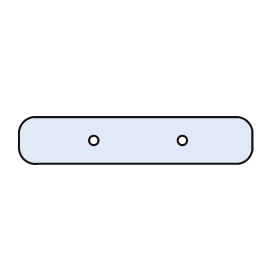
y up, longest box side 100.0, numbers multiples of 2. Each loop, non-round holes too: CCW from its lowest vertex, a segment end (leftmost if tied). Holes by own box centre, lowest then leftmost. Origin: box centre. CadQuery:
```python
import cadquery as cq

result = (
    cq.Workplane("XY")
    .moveTo(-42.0, -10.0)
    .lineTo(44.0, -10.0)
    .threePointArc((48.0, -8.0), (50.0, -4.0))
    .lineTo(50.0, 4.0)
    .threePointArc((48.0, 8.0), (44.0, 10.0))
    .lineTo(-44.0, 10.0)
    .threePointArc((-48.0, 8.0), (-50.0, 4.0))
    .lineTo(-50.0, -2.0)
    .threePointArc((-48.0, -8.0), (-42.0, -10.0))
    .close()
    .moveTo(-18.0, 0.0)
    .circle(2.0)
    .moveTo(20.0, 0.0)
    .circle(2.0)
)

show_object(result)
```